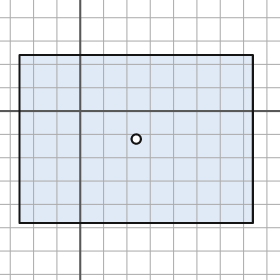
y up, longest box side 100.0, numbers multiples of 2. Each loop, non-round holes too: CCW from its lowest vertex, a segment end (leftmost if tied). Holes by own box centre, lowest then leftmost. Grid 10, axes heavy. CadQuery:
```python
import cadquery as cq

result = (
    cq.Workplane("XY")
    .moveTo(-26.0, -48.0)
    .lineTo(74.0, -48.0)
    .lineTo(74.0, 24.0)
    .lineTo(-26.0, 24.0)
    .close()
    .moveTo(24.0, -12.0)
    .circle(2.0)
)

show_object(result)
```